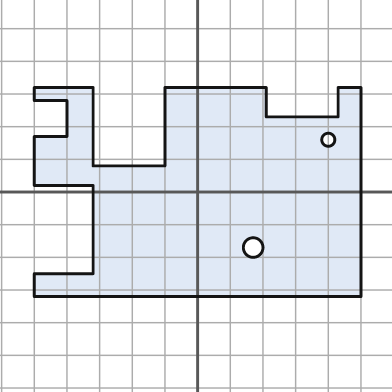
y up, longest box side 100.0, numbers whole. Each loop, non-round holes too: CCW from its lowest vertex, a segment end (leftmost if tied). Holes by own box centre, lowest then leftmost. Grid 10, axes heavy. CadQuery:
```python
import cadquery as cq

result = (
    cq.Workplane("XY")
    .moveTo(-50.0, -32.0)
    .lineTo(50.0, -32.0)
    .lineTo(50.0, 32.0)
    .lineTo(43.0, 32.0)
    .lineTo(43.0, 23.0)
    .lineTo(21.0, 23.0)
    .lineTo(21.0, 32.0)
    .lineTo(-10.0, 32.0)
    .lineTo(-10.0, 8.0)
    .lineTo(-32.0, 8.0)
    .lineTo(-32.0, 32.0)
    .lineTo(-50.0, 32.0)
    .lineTo(-50.0, 28.0)
    .lineTo(-40.0, 28.0)
    .lineTo(-40.0, 17.0)
    .lineTo(-50.0, 17.0)
    .lineTo(-50.0, 2.0)
    .lineTo(-32.0, 2.0)
    .lineTo(-32.0, -25.0)
    .lineTo(-50.0, -25.0)
    .close()
    .moveTo(17.0, -17.0)
    .circle(3.0)
    .moveTo(40.0, 16.0)
    .circle(2.0)
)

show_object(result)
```